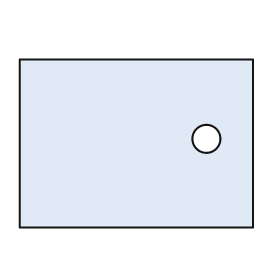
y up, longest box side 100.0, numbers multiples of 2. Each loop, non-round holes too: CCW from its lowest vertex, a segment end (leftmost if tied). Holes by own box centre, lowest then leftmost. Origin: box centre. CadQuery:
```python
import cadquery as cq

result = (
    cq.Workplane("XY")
    .moveTo(-50.0, -36.0)
    .lineTo(50.0, -36.0)
    .lineTo(50.0, 36.0)
    .lineTo(-50.0, 36.0)
    .close()
    .moveTo(30.0, 2.0)
    .circle(6.0)
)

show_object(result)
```